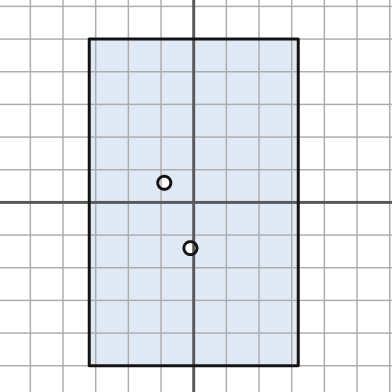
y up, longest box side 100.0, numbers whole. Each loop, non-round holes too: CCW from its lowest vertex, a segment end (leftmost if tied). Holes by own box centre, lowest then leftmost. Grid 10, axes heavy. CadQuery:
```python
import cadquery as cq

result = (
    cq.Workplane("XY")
    .moveTo(-32.0, -50.0)
    .lineTo(32.0, -50.0)
    .lineTo(32.0, 50.0)
    .lineTo(-32.0, 50.0)
    .close()
    .moveTo(-1.0, -14.0)
    .circle(2.0)
    .moveTo(-9.0, 6.0)
    .circle(2.0)
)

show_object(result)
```